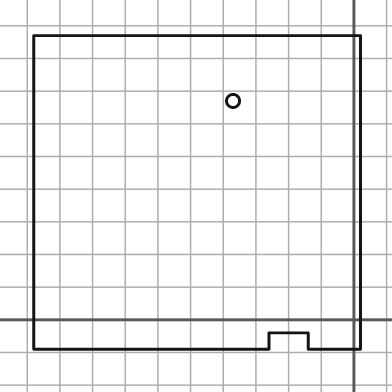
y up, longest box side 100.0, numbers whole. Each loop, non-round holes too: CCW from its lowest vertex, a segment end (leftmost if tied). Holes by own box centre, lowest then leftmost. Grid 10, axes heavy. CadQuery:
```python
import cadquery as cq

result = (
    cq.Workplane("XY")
    .moveTo(-98.0, -9.0)
    .lineTo(-26.0, -9.0)
    .lineTo(-26.0, -4.0)
    .lineTo(-14.0, -4.0)
    .lineTo(-14.0, -9.0)
    .lineTo(2.0, -9.0)
    .lineTo(2.0, 87.0)
    .lineTo(-98.0, 87.0)
    .close()
    .moveTo(-37.0, 67.0)
    .circle(2.0)
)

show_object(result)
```